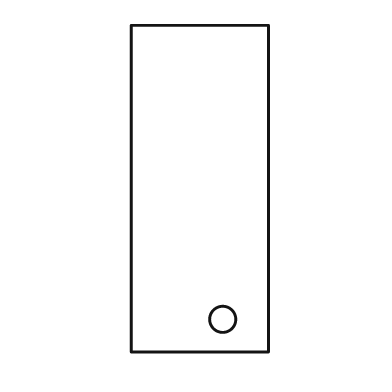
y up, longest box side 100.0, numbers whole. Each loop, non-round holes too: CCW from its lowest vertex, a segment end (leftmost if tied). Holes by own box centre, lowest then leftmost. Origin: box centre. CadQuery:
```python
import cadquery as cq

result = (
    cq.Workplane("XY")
    .moveTo(-21.0, -50.0)
    .lineTo(21.0, -50.0)
    .lineTo(21.0, 50.0)
    .lineTo(-21.0, 50.0)
    .close()
    .moveTo(7.0, -40.0)
    .circle(4.0)
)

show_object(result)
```